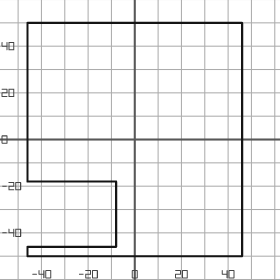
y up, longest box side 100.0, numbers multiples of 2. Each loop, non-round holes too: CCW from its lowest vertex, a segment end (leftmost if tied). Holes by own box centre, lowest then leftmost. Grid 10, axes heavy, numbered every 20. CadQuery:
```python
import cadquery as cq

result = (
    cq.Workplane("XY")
    .moveTo(-46.0, -50.0)
    .lineTo(46.0, -50.0)
    .lineTo(46.0, 50.0)
    .lineTo(-46.0, 50.0)
    .lineTo(-46.0, -18.0)
    .lineTo(-8.0, -18.0)
    .lineTo(-8.0, -46.0)
    .lineTo(-46.0, -46.0)
    .close()
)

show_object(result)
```